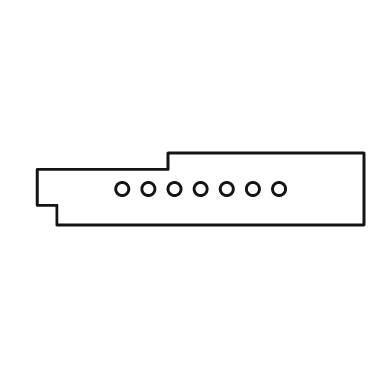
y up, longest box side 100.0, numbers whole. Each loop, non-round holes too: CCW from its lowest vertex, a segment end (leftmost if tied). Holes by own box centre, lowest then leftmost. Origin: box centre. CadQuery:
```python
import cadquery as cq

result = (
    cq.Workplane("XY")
    .moveTo(-44.0, -11.0)
    .lineTo(50.0, -11.0)
    .lineTo(50.0, 11.0)
    .lineTo(-10.0, 11.0)
    .lineTo(-10.0, 6.0)
    .lineTo(-50.0, 6.0)
    .lineTo(-50.0, -5.0)
    .lineTo(-44.0, -5.0)
    .close()
    .moveTo(-24.0, 0.0)
    .circle(2.0)
    .moveTo(-16.0, 0.0)
    .circle(2.0)
    .moveTo(-8.0, 0.0)
    .circle(2.0)
    .moveTo(0.0, 0.0)
    .circle(2.0)
    .moveTo(8.0, 0.0)
    .circle(2.0)
    .moveTo(16.0, 0.0)
    .circle(2.0)
    .moveTo(24.0, 0.0)
    .circle(2.0)
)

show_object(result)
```